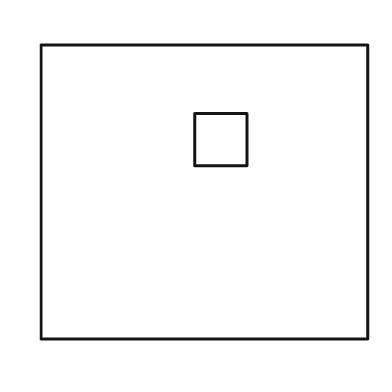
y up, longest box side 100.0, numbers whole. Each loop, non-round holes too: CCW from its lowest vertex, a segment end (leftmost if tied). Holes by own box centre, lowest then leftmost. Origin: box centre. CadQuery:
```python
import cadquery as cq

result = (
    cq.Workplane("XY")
    .moveTo(-50.0, -45.0)
    .lineTo(50.0, -45.0)
    .lineTo(50.0, 45.0)
    .lineTo(-50.0, 45.0)
    .close()
    .moveTo(-3.0, 8.0)
    .lineTo(13.0, 8.0)
    .lineTo(13.0, 24.0)
    .lineTo(-3.0, 24.0)
    .close()
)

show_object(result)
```